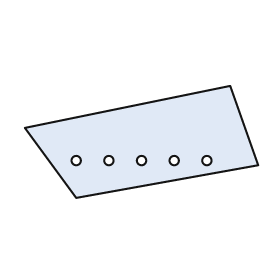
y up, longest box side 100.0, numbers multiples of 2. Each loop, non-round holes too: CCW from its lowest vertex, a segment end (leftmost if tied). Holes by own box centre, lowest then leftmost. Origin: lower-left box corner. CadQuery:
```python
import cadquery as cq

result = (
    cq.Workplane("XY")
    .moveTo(22.0, 0.0)
    .lineTo(100.0, 14.0)
    .lineTo(88.0, 48.0)
    .lineTo(0.0, 30.0)
    .close()
    .moveTo(22.0, 16.0)
    .circle(2.0)
    .moveTo(36.0, 16.0)
    .circle(2.0)
    .moveTo(50.0, 16.0)
    .circle(2.0)
    .moveTo(64.0, 16.0)
    .circle(2.0)
    .moveTo(78.0, 16.0)
    .circle(2.0)
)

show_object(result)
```